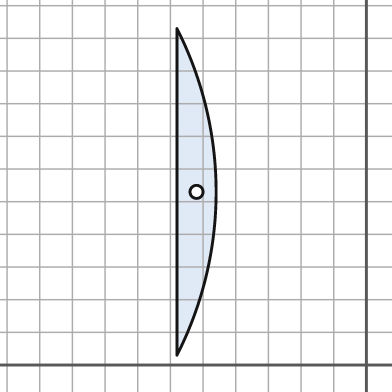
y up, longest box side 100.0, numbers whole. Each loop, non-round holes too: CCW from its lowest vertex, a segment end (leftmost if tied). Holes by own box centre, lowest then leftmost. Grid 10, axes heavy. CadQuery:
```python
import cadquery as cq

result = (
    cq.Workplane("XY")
    .moveTo(-58.0, 3.0)
    .threePointArc((-46.0, 53.0), (-58.0, 103.0))
    .close()
    .moveTo(-52.0, 53.0)
    .circle(2.0)
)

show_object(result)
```